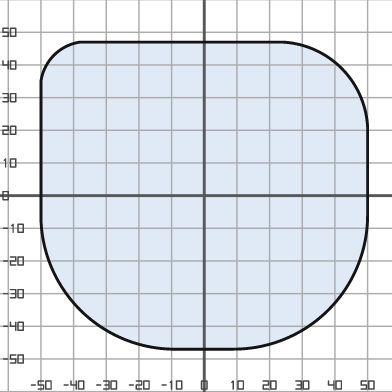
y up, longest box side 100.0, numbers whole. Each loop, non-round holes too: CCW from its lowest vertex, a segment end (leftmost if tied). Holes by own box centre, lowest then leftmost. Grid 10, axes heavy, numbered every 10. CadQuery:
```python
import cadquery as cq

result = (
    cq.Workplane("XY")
    .moveTo(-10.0, -47.0)
    .lineTo(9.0, -47.0)
    .threePointArc((38.0, -35.0), (50.0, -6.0))
    .lineTo(50.0, 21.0)
    .threePointArc((42.0, 39.0), (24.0, 47.0))
    .lineTo(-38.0, 47.0)
    .threePointArc((-46.0, 43.0), (-50.0, 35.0))
    .lineTo(-50.0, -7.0)
    .threePointArc((-38.0, -35.0), (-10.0, -47.0))
    .close()
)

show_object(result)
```